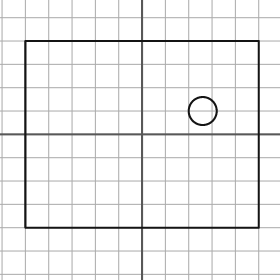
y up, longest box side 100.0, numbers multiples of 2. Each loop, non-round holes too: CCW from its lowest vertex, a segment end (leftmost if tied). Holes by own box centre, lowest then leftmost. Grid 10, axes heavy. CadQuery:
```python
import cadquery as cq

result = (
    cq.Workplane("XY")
    .moveTo(-50.0, -40.0)
    .lineTo(50.0, -40.0)
    .lineTo(50.0, 40.0)
    .lineTo(-50.0, 40.0)
    .close()
    .moveTo(26.0, 10.0)
    .circle(6.0)
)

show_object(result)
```